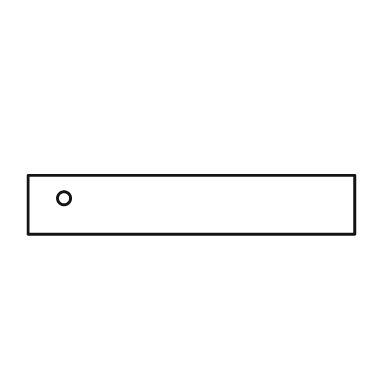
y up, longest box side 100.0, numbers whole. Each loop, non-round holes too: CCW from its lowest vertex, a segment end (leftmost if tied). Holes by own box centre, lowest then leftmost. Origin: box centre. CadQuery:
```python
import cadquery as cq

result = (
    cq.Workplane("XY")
    .moveTo(-50.0, -9.0)
    .lineTo(50.0, -9.0)
    .lineTo(50.0, 9.0)
    .lineTo(-50.0, 9.0)
    .close()
    .moveTo(-39.0, 2.0)
    .circle(2.0)
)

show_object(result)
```